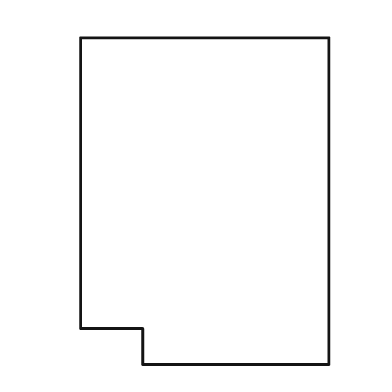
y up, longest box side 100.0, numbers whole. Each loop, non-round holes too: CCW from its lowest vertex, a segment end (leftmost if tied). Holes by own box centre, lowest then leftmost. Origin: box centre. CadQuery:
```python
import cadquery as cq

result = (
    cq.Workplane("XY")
    .moveTo(-19.0, -50.0)
    .lineTo(38.0, -50.0)
    .lineTo(38.0, 50.0)
    .lineTo(-38.0, 50.0)
    .lineTo(-38.0, -39.0)
    .lineTo(-19.0, -39.0)
    .close()
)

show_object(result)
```